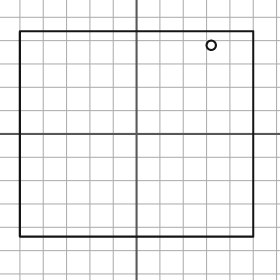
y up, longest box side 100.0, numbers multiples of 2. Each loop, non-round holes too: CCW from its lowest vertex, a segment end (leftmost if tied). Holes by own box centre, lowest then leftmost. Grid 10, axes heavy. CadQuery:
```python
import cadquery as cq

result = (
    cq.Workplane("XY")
    .moveTo(-50.0, -44.0)
    .lineTo(50.0, -44.0)
    .lineTo(50.0, 44.0)
    .lineTo(-50.0, 44.0)
    .close()
    .moveTo(32.0, 38.0)
    .circle(2.0)
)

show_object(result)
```